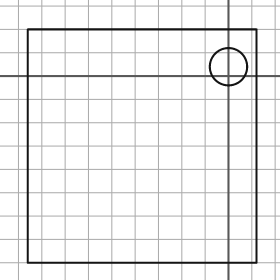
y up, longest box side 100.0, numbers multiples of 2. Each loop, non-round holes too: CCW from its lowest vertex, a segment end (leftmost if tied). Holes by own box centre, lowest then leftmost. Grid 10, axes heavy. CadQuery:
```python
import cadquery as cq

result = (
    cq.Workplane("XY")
    .moveTo(-86.0, -80.0)
    .lineTo(12.0, -80.0)
    .lineTo(12.0, 20.0)
    .lineTo(-86.0, 20.0)
    .close()
    .moveTo(0.0, 4.0)
    .circle(8.0)
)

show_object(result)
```